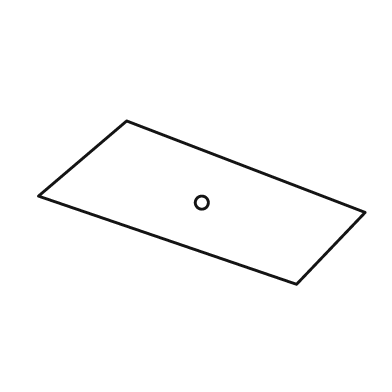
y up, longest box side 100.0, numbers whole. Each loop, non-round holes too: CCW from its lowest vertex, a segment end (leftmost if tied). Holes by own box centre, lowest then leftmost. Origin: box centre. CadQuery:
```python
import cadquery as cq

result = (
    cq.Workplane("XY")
    .moveTo(29.0, -25.0)
    .lineTo(50.0, -3.0)
    .lineTo(-23.0, 25.0)
    .lineTo(-50.0, 2.0)
    .close()
    .moveTo(0.0, 0.0)
    .circle(2.0)
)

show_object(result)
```